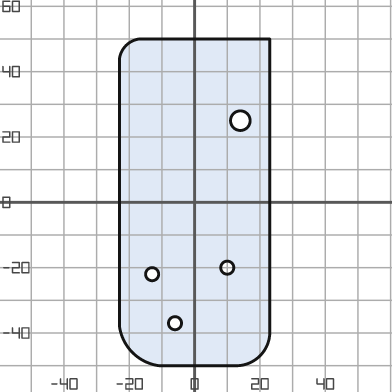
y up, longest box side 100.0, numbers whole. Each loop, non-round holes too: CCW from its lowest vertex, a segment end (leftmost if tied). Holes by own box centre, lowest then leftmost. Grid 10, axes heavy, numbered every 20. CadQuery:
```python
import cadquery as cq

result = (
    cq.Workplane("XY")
    .moveTo(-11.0, -50.0)
    .lineTo(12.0, -50.0)
    .threePointArc((20.0, -47.0), (23.0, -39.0))
    .lineTo(23.0, 50.0)
    .lineTo(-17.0, 50.0)
    .threePointArc((-21.0, 48.0), (-23.0, 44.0))
    .lineTo(-23.0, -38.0)
    .threePointArc((-19.0, -46.0), (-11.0, -50.0))
    .close()
    .moveTo(-6.0, -37.0)
    .circle(2.0)
    .moveTo(-13.0, -22.0)
    .circle(2.0)
    .moveTo(10.0, -20.0)
    .circle(2.0)
    .moveTo(14.0, 25.0)
    .circle(3.0)
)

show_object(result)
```